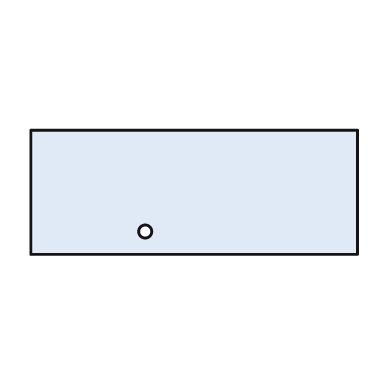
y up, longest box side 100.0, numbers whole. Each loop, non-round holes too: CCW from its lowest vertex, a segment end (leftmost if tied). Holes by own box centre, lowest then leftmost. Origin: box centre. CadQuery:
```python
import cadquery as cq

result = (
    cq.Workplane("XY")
    .moveTo(-50.0, -19.0)
    .lineTo(50.0, -19.0)
    .lineTo(50.0, 19.0)
    .lineTo(-50.0, 19.0)
    .close()
    .moveTo(-15.0, -12.0)
    .circle(2.0)
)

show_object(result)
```